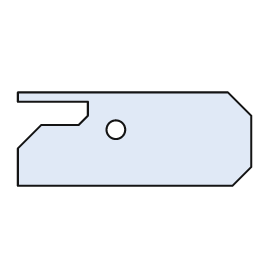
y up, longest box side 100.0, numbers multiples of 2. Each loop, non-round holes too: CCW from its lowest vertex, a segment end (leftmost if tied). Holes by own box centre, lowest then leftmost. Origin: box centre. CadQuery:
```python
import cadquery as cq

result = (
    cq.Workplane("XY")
    .moveTo(-50.0, -20.0)
    .lineTo(42.0, -20.0)
    .lineTo(50.0, -12.0)
    .lineTo(50.0, 10.0)
    .lineTo(40.0, 20.0)
    .lineTo(-50.0, 20.0)
    .lineTo(-50.0, 16.0)
    .lineTo(-20.0, 16.0)
    .lineTo(-20.0, 10.0)
    .lineTo(-24.0, 6.0)
    .lineTo(-40.0, 6.0)
    .lineTo(-50.0, -4.0)
    .close()
    .moveTo(-8.0, 4.0)
    .circle(4.0)
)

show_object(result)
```